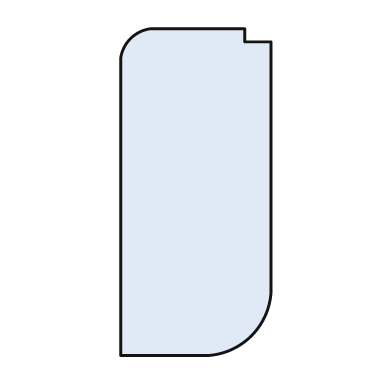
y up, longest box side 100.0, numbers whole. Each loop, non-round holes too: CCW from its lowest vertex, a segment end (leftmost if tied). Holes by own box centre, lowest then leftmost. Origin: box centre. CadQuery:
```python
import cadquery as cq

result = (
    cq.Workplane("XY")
    .moveTo(-23.0, -50.0)
    .lineTo(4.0, -50.0)
    .threePointArc((17.0, -44.0), (23.0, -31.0))
    .lineTo(23.0, 46.0)
    .lineTo(15.0, 46.0)
    .lineTo(15.0, 50.0)
    .lineTo(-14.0, 50.0)
    .threePointArc((-20.0, 47.0), (-23.0, 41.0))
    .close()
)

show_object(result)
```